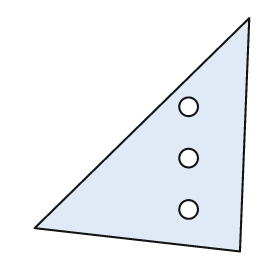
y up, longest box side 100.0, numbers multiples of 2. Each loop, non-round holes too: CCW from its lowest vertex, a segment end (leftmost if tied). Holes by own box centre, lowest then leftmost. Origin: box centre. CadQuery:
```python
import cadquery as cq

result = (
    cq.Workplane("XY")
    .moveTo(42.0, -50.0)
    .lineTo(46.0, 50.0)
    .lineTo(-46.0, -40.0)
    .close()
    .moveTo(20.0, -32.0)
    .circle(4.0)
    .moveTo(20.0, -10.0)
    .circle(4.0)
    .moveTo(20.0, 12.0)
    .circle(4.0)
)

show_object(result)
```